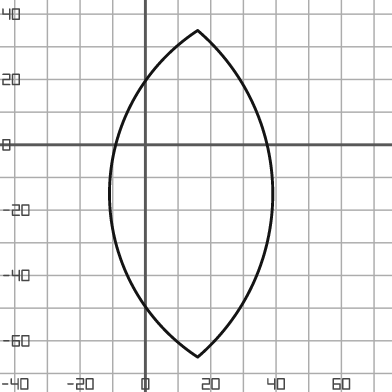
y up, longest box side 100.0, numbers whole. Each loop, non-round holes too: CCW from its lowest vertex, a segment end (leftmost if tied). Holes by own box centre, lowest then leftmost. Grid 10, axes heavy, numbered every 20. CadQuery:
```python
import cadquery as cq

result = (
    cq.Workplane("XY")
    .moveTo(16.0, -65.0)
    .threePointArc((39.0, -15.0), (16.0, 35.0))
    .threePointArc((-11.0, -15.0), (16.0, -65.0))
    .close()
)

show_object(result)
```